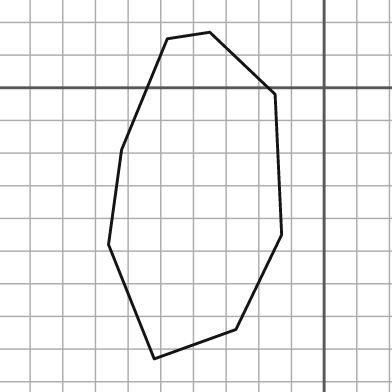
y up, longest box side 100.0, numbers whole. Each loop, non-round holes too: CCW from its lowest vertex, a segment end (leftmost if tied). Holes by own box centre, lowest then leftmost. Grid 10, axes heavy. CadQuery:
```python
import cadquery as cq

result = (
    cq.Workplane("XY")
    .moveTo(-52.0, -83.0)
    .lineTo(-27.0, -74.0)
    .lineTo(-13.0, -45.0)
    .lineTo(-15.0, -2.0)
    .lineTo(-35.0, 17.0)
    .lineTo(-48.0, 15.0)
    .lineTo(-62.0, -19.0)
    .lineTo(-66.0, -48.0)
    .close()
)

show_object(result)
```